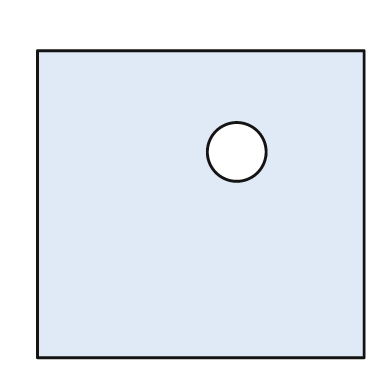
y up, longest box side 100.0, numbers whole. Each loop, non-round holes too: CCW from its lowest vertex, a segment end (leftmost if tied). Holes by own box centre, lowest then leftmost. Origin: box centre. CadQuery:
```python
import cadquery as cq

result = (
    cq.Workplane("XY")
    .moveTo(-50.0, -47.0)
    .lineTo(50.0, -47.0)
    .lineTo(50.0, 47.0)
    .lineTo(-50.0, 47.0)
    .close()
    .moveTo(11.0, 16.0)
    .circle(9.0)
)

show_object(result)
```